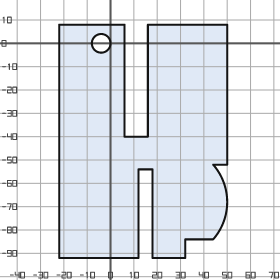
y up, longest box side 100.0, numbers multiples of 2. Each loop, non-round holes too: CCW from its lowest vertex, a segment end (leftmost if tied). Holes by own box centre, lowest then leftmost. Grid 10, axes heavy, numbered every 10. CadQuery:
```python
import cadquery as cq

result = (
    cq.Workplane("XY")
    .moveTo(-22.0, -92.0)
    .lineTo(12.0, -92.0)
    .lineTo(12.0, -54.0)
    .lineTo(18.0, -54.0)
    .lineTo(18.0, -92.0)
    .lineTo(32.0, -92.0)
    .lineTo(32.0, -84.0)
    .lineTo(44.0, -84.0)
    .threePointArc((50.0, -68.0), (44.0, -52.0))
    .lineTo(50.0, -52.0)
    .lineTo(50.0, 8.0)
    .lineTo(16.0, 8.0)
    .lineTo(16.0, -40.0)
    .lineTo(6.0, -40.0)
    .lineTo(6.0, 8.0)
    .lineTo(-22.0, 8.0)
    .close()
    .moveTo(-4.0, 0.0)
    .circle(4.0)
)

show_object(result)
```